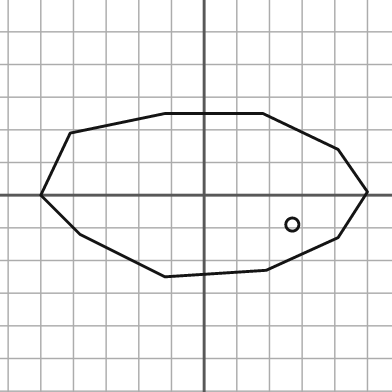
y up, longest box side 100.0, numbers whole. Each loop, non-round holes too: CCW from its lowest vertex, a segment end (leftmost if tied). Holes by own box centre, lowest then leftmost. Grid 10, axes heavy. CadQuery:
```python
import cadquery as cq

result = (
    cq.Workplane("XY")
    .moveTo(-12.0, -25.0)
    .lineTo(19.0, -23.0)
    .lineTo(41.0, -13.0)
    .lineTo(50.0, 1.0)
    .lineTo(41.0, 14.0)
    .lineTo(18.0, 25.0)
    .lineTo(-12.0, 25.0)
    .lineTo(-41.0, 19.0)
    .lineTo(-50.0, 0.0)
    .lineTo(-38.0, -12.0)
    .close()
    .moveTo(27.0, -9.0)
    .circle(2.0)
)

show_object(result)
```